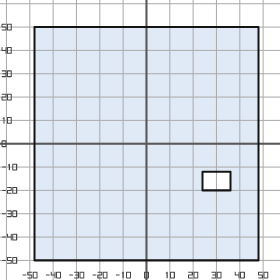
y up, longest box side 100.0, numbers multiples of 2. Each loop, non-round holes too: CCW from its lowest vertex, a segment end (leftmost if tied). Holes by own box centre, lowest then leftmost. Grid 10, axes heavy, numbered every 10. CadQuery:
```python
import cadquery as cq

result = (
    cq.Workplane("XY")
    .moveTo(-48.0, -50.0)
    .lineTo(48.0, -50.0)
    .lineTo(48.0, 50.0)
    .lineTo(-48.0, 50.0)
    .close()
    .moveTo(24.0, -20.0)
    .lineTo(36.0, -20.0)
    .lineTo(36.0, -12.0)
    .lineTo(24.0, -12.0)
    .close()
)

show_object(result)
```